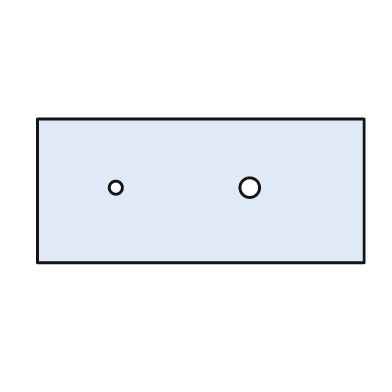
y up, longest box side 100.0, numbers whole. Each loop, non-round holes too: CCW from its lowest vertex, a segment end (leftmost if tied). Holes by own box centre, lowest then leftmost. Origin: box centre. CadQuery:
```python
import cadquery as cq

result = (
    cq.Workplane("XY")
    .moveTo(-50.0, -22.0)
    .lineTo(50.0, -22.0)
    .lineTo(50.0, 22.0)
    .lineTo(-50.0, 22.0)
    .close()
    .moveTo(-26.0, 1.0)
    .circle(2.0)
    .moveTo(15.0, 1.0)
    .circle(3.0)
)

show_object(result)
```